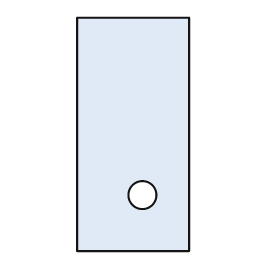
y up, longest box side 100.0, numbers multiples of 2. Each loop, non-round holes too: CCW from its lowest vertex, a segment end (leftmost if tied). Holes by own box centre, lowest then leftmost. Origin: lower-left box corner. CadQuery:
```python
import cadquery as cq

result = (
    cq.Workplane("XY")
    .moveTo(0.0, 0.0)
    .lineTo(48.0, 0.0)
    .lineTo(48.0, 100.0)
    .lineTo(0.0, 100.0)
    .close()
    .moveTo(28.0, 24.0)
    .circle(6.0)
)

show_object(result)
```